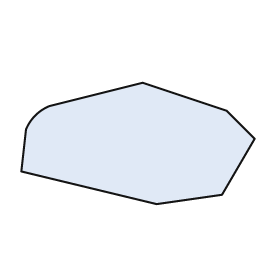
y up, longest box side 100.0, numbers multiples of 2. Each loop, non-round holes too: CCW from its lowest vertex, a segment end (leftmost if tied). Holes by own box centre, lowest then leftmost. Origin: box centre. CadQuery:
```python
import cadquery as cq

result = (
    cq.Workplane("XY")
    .moveTo(8.0, -26.0)
    .lineTo(36.0, -22.0)
    .lineTo(50.0, 2.0)
    .lineTo(38.0, 14.0)
    .lineTo(2.0, 26.0)
    .lineTo(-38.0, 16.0)
    .threePointArc((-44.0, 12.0), (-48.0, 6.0))
    .lineTo(-50.0, -12.0)
    .close()
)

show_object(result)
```